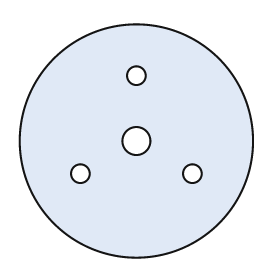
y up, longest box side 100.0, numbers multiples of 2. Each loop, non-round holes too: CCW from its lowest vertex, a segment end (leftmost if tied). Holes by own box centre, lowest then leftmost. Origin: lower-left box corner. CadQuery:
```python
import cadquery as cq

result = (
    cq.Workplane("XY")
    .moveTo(50.0, 50.0)
    .circle(50.0)
    .moveTo(26.0, 36.0)
    .circle(4.0)
    .moveTo(74.0, 36.0)
    .circle(4.0)
    .moveTo(50.0, 50.0)
    .circle(6.0)
    .moveTo(50.0, 78.0)
    .circle(4.0)
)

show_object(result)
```